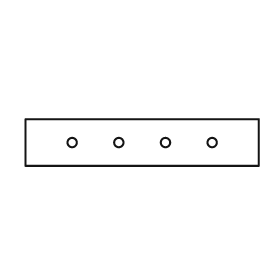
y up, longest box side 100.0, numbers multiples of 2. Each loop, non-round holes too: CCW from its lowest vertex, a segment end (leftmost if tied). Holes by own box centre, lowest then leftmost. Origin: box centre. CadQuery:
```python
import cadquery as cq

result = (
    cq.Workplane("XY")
    .moveTo(-50.0, -10.0)
    .lineTo(50.0, -10.0)
    .lineTo(50.0, 10.0)
    .lineTo(-50.0, 10.0)
    .close()
    .moveTo(-30.0, 0.0)
    .circle(2.0)
    .moveTo(-10.0, 0.0)
    .circle(2.0)
    .moveTo(10.0, 0.0)
    .circle(2.0)
    .moveTo(30.0, 0.0)
    .circle(2.0)
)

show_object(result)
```